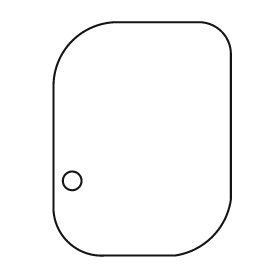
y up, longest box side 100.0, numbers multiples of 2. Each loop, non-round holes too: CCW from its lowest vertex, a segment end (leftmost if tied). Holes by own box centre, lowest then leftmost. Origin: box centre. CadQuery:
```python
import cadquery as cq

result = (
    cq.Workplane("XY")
    .moveTo(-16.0, -50.0)
    .lineTo(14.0, -50.0)
    .threePointArc((30.0, -42.0), (38.0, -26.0))
    .lineTo(38.0, 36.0)
    .threePointArc((34.0, 46.0), (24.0, 50.0))
    .lineTo(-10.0, 50.0)
    .threePointArc((-30.0, 42.0), (-38.0, 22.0))
    .lineTo(-38.0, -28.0)
    .threePointArc((-32.0, -44.0), (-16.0, -50.0))
    .close()
    .moveTo(-30.0, -18.0)
    .circle(4.0)
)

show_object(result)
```